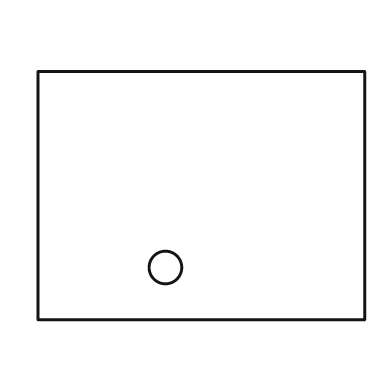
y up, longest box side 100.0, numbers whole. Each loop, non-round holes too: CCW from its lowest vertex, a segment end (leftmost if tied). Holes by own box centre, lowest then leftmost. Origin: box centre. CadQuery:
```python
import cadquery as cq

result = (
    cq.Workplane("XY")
    .moveTo(-50.0, -38.0)
    .lineTo(50.0, -38.0)
    .lineTo(50.0, 38.0)
    .lineTo(-50.0, 38.0)
    .close()
    .moveTo(-11.0, -22.0)
    .circle(5.0)
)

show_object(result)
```